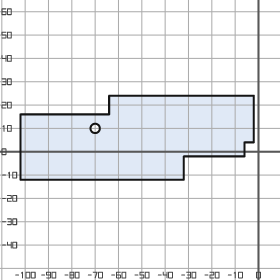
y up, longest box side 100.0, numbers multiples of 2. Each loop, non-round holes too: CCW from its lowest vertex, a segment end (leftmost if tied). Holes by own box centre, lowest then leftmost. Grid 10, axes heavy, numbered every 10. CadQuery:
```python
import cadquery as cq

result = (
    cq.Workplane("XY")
    .moveTo(-102.0, -12.0)
    .lineTo(-32.0, -12.0)
    .lineTo(-32.0, -2.0)
    .lineTo(-6.0, -2.0)
    .lineTo(-6.0, 4.0)
    .lineTo(-2.0, 4.0)
    .lineTo(-2.0, 24.0)
    .lineTo(-64.0, 24.0)
    .lineTo(-64.0, 16.0)
    .lineTo(-102.0, 16.0)
    .close()
    .moveTo(-70.0, 10.0)
    .circle(2.0)
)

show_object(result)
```